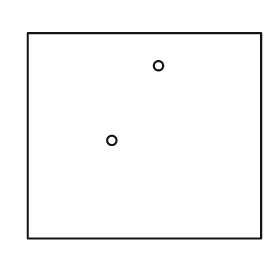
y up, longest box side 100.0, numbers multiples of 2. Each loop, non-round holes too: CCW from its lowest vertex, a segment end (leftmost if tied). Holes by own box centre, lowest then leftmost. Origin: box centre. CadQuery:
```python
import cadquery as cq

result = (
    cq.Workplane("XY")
    .moveTo(-50.0, -44.0)
    .lineTo(50.0, -44.0)
    .lineTo(50.0, 44.0)
    .lineTo(-50.0, 44.0)
    .close()
    .moveTo(-14.0, -2.0)
    .circle(2.0)
    .moveTo(6.0, 30.0)
    .circle(2.0)
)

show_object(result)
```